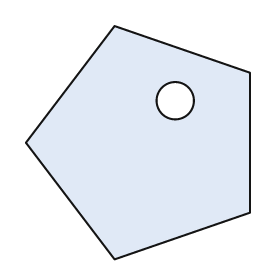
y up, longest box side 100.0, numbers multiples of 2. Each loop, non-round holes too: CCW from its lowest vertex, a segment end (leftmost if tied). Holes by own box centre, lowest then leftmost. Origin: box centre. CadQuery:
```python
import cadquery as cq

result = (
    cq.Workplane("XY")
    .moveTo(-10.0, -50.0)
    .lineTo(48.0, -30.0)
    .lineTo(48.0, 30.0)
    .lineTo(-10.0, 50.0)
    .lineTo(-48.0, 0.0)
    .close()
    .moveTo(16.0, 18.0)
    .circle(8.0)
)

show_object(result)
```